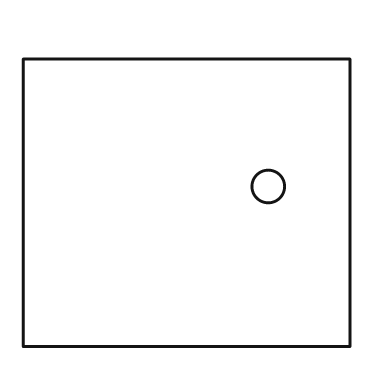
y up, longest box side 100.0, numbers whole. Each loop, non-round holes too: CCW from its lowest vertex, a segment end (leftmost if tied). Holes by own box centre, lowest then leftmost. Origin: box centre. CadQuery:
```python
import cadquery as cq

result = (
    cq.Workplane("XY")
    .moveTo(-50.0, -44.0)
    .lineTo(50.0, -44.0)
    .lineTo(50.0, 44.0)
    .lineTo(-50.0, 44.0)
    .close()
    .moveTo(25.0, 5.0)
    .circle(5.0)
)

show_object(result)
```